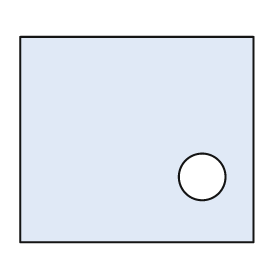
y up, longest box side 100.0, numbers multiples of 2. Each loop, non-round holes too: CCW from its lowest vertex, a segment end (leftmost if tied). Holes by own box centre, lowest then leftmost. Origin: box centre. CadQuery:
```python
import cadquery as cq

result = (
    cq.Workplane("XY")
    .moveTo(-50.0, -44.0)
    .lineTo(50.0, -44.0)
    .lineTo(50.0, 44.0)
    .lineTo(-50.0, 44.0)
    .close()
    .moveTo(28.0, -16.0)
    .circle(10.0)
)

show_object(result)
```